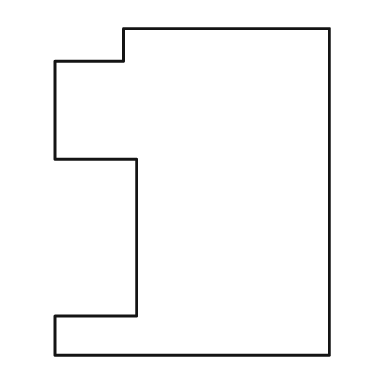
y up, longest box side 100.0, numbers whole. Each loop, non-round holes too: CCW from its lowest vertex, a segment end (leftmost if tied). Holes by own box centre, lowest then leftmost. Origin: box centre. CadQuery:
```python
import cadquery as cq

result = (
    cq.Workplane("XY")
    .moveTo(-42.0, -50.0)
    .lineTo(42.0, -50.0)
    .lineTo(42.0, 50.0)
    .lineTo(-21.0, 50.0)
    .lineTo(-21.0, 40.0)
    .lineTo(-42.0, 40.0)
    .lineTo(-42.0, 10.0)
    .lineTo(-17.0, 10.0)
    .lineTo(-17.0, -38.0)
    .lineTo(-42.0, -38.0)
    .close()
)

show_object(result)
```